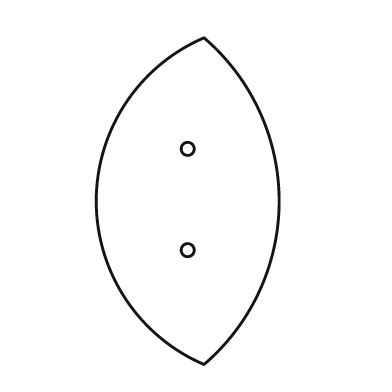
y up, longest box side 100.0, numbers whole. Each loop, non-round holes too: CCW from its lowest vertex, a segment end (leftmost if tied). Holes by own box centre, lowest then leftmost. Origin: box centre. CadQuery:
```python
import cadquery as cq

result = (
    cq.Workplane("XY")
    .moveTo(5.0, -50.0)
    .threePointArc((28.0, 0.0), (5.0, 50.0))
    .threePointArc((-28.0, 0.0), (5.0, -50.0))
    .close()
    .moveTo(0.0, -15.0)
    .circle(2.0)
    .moveTo(0.0, 16.0)
    .circle(2.0)
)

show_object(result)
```